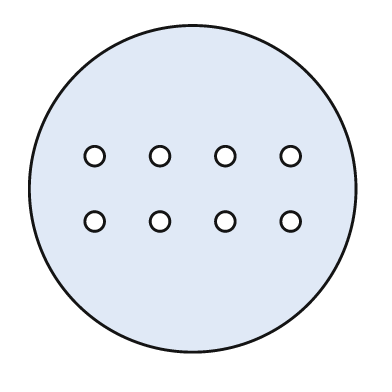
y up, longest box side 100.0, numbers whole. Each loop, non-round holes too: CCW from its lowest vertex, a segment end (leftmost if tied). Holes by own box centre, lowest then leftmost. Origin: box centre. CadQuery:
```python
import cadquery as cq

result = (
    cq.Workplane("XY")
    .moveTo(0.0, 0.0)
    .circle(50.0)
    .moveTo(-30.0, -10.0)
    .circle(3.0)
    .moveTo(-10.0, -10.0)
    .circle(3.0)
    .moveTo(10.0, -10.0)
    .circle(3.0)
    .moveTo(30.0, -10.0)
    .circle(3.0)
    .moveTo(-30.0, 10.0)
    .circle(3.0)
    .moveTo(-10.0, 10.0)
    .circle(3.0)
    .moveTo(10.0, 10.0)
    .circle(3.0)
    .moveTo(30.0, 10.0)
    .circle(3.0)
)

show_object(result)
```